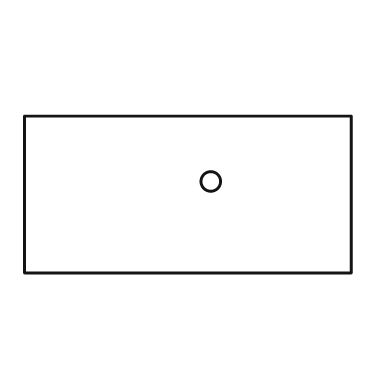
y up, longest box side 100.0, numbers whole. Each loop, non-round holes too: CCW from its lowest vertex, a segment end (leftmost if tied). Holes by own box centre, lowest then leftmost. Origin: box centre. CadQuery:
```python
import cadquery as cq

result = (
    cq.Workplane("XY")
    .moveTo(-50.0, -24.0)
    .lineTo(50.0, -24.0)
    .lineTo(50.0, 24.0)
    .lineTo(-50.0, 24.0)
    .close()
    .moveTo(7.0, 4.0)
    .circle(3.0)
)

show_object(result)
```